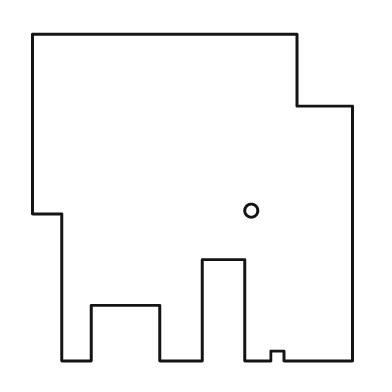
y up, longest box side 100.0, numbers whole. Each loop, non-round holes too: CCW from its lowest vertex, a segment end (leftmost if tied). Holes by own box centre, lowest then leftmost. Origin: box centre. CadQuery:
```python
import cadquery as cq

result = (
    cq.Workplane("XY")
    .moveTo(-40.0, -50.0)
    .lineTo(-31.0, -50.0)
    .lineTo(-31.0, -33.0)
    .lineTo(-10.0, -33.0)
    .lineTo(-10.0, -50.0)
    .lineTo(3.0, -50.0)
    .lineTo(3.0, -19.0)
    .lineTo(16.0, -19.0)
    .lineTo(16.0, -50.0)
    .lineTo(24.0, -50.0)
    .lineTo(24.0, -47.0)
    .lineTo(28.0, -47.0)
    .lineTo(28.0, -50.0)
    .lineTo(49.0, -50.0)
    .lineTo(49.0, 28.0)
    .lineTo(32.0, 28.0)
    .lineTo(32.0, 50.0)
    .lineTo(-49.0, 50.0)
    .lineTo(-49.0, -5.0)
    .lineTo(-40.0, -5.0)
    .close()
    .moveTo(18.0, -4.0)
    .circle(2.0)
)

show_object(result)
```